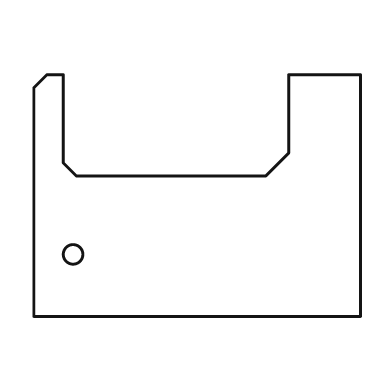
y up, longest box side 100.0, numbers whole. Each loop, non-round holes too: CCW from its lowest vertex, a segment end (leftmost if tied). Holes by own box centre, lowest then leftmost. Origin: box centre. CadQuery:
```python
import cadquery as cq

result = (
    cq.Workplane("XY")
    .moveTo(-50.0, -37.0)
    .lineTo(50.0, -37.0)
    .lineTo(50.0, 37.0)
    .lineTo(28.0, 37.0)
    .lineTo(28.0, 13.0)
    .lineTo(21.0, 6.0)
    .lineTo(-37.0, 6.0)
    .lineTo(-41.0, 10.0)
    .lineTo(-41.0, 37.0)
    .lineTo(-46.0, 37.0)
    .lineTo(-50.0, 33.0)
    .close()
    .moveTo(-38.0, -18.0)
    .circle(3.0)
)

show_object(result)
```